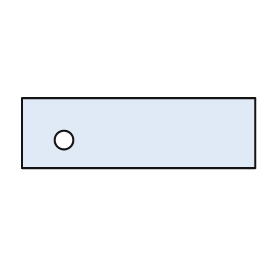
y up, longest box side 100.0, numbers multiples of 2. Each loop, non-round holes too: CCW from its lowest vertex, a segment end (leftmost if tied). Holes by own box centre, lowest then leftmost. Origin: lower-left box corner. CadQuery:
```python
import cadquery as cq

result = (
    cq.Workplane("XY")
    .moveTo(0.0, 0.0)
    .lineTo(100.0, 0.0)
    .lineTo(100.0, 30.0)
    .lineTo(0.0, 30.0)
    .close()
    .moveTo(18.0, 12.0)
    .circle(4.0)
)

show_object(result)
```